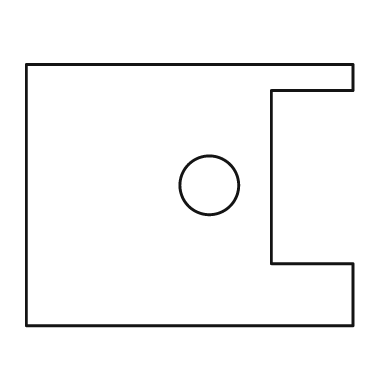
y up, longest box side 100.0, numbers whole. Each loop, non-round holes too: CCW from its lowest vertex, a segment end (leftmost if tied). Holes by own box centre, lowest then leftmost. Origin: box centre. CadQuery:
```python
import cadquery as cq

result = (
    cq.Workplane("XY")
    .moveTo(-50.0, -40.0)
    .lineTo(50.0, -40.0)
    .lineTo(50.0, -21.0)
    .lineTo(25.0, -21.0)
    .lineTo(25.0, 32.0)
    .lineTo(50.0, 32.0)
    .lineTo(50.0, 40.0)
    .lineTo(-50.0, 40.0)
    .close()
    .moveTo(6.0, 3.0)
    .circle(9.0)
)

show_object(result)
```